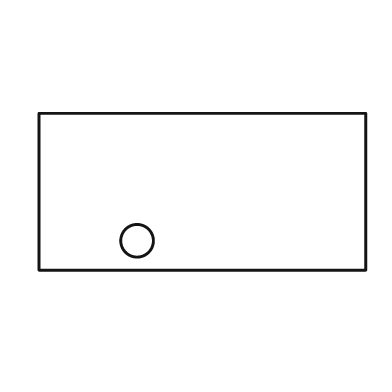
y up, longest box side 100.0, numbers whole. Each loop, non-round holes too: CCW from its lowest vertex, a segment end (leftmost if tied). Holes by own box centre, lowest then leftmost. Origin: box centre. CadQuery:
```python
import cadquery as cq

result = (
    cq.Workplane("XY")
    .moveTo(-50.0, -24.0)
    .lineTo(50.0, -24.0)
    .lineTo(50.0, 24.0)
    .lineTo(-50.0, 24.0)
    .close()
    .moveTo(-20.0, -15.0)
    .circle(5.0)
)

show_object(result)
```